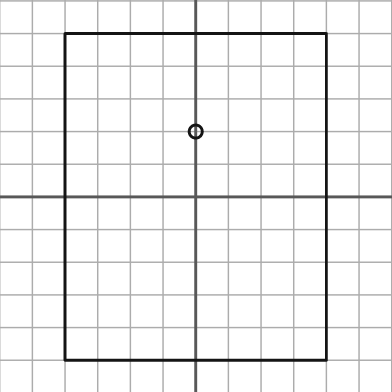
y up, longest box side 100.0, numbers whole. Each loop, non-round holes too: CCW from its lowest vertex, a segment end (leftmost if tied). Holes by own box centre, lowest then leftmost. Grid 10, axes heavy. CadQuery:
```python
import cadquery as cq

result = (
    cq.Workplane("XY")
    .moveTo(-40.0, -50.0)
    .lineTo(40.0, -50.0)
    .lineTo(40.0, 50.0)
    .lineTo(-40.0, 50.0)
    .close()
    .moveTo(0.0, 20.0)
    .circle(2.0)
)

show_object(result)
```